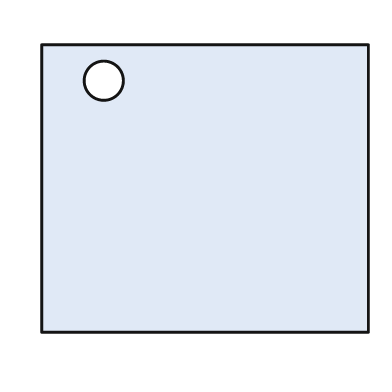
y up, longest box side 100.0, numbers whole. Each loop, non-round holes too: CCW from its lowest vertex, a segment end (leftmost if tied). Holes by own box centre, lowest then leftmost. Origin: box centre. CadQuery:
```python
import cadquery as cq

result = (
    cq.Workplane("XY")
    .moveTo(-50.0, -44.0)
    .lineTo(50.0, -44.0)
    .lineTo(50.0, 44.0)
    .lineTo(-50.0, 44.0)
    .close()
    .moveTo(-31.0, 33.0)
    .circle(6.0)
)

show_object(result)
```